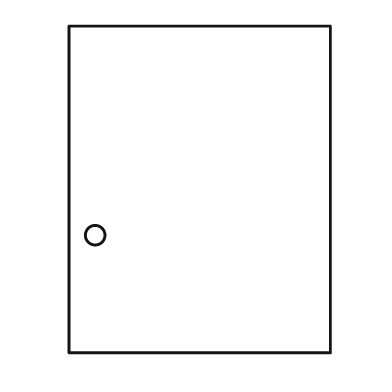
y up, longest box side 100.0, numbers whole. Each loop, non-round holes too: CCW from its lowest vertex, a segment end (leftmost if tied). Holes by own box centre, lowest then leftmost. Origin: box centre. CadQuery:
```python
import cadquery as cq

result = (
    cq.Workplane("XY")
    .moveTo(-40.0, -50.0)
    .lineTo(40.0, -50.0)
    .lineTo(40.0, 50.0)
    .lineTo(-40.0, 50.0)
    .close()
    .moveTo(-32.0, -14.0)
    .circle(3.0)
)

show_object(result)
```